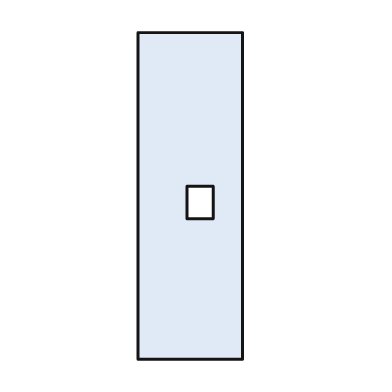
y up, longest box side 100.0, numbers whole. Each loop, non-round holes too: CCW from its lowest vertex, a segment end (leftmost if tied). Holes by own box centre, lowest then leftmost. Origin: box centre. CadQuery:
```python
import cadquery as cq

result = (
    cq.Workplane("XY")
    .moveTo(-16.0, -50.0)
    .lineTo(16.0, -50.0)
    .lineTo(16.0, 50.0)
    .lineTo(-16.0, 50.0)
    .close()
    .moveTo(-1.0, -7.0)
    .lineTo(7.0, -7.0)
    .lineTo(7.0, 3.0)
    .lineTo(-1.0, 3.0)
    .close()
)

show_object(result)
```